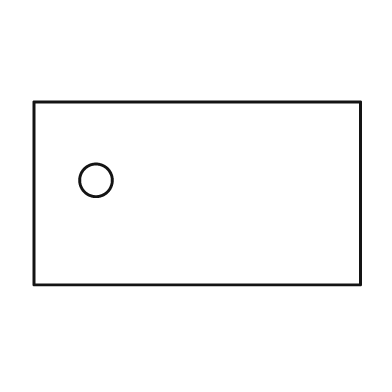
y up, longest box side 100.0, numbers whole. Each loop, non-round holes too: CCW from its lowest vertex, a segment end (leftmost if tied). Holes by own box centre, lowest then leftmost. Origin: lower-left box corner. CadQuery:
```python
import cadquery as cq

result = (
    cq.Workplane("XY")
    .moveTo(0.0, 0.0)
    .lineTo(100.0, 0.0)
    .lineTo(100.0, 56.0)
    .lineTo(0.0, 56.0)
    .close()
    .moveTo(19.0, 32.0)
    .circle(5.0)
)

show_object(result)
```